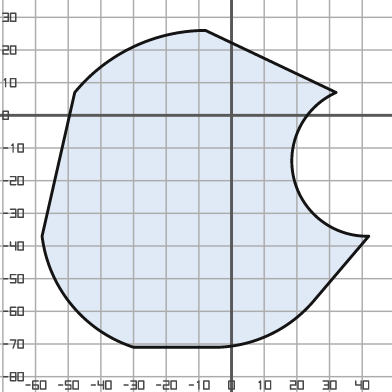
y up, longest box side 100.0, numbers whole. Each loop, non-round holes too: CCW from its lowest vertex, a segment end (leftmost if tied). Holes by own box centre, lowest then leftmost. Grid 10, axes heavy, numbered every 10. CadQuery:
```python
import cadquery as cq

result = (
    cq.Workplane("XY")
    .moveTo(-30.0, -71.0)
    .lineTo(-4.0, -71.0)
    .threePointArc((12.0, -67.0), (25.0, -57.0))
    .lineTo(42.0, -37.0)
    .threePointArc((19.0, -19.0), (32.0, 7.0))
    .lineTo(-8.0, 26.0)
    .threePointArc((-30.0, 21.0), (-48.0, 7.0))
    .lineTo(-58.0, -37.0)
    .threePointArc((-49.0, -58.0), (-30.0, -71.0))
    .close()
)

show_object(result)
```